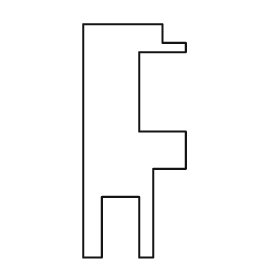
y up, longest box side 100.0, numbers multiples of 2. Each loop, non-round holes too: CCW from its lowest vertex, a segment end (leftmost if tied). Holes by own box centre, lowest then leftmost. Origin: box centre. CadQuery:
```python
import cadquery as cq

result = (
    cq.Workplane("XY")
    .moveTo(-22.0, -50.0)
    .lineTo(-14.0, -50.0)
    .lineTo(-14.0, -24.0)
    .lineTo(2.0, -24.0)
    .lineTo(2.0, -50.0)
    .lineTo(8.0, -50.0)
    .lineTo(8.0, -12.0)
    .lineTo(22.0, -12.0)
    .lineTo(22.0, 4.0)
    .lineTo(2.0, 4.0)
    .lineTo(2.0, 38.0)
    .lineTo(22.0, 38.0)
    .lineTo(22.0, 42.0)
    .lineTo(12.0, 42.0)
    .lineTo(12.0, 50.0)
    .lineTo(-22.0, 50.0)
    .close()
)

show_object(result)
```